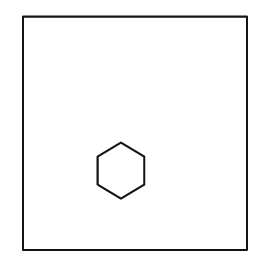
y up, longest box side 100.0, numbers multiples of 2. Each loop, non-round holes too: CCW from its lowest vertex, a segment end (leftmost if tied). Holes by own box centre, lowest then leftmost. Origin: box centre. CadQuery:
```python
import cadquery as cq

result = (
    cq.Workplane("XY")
    .moveTo(-48.0, -50.0)
    .lineTo(48.0, -50.0)
    .lineTo(48.0, 50.0)
    .lineTo(-48.0, 50.0)
    .close()
    .moveTo(-6.0, -28.0)
    .lineTo(4.0, -22.0)
    .lineTo(4.0, -10.0)
    .lineTo(-6.0, -4.0)
    .lineTo(-16.0, -10.0)
    .lineTo(-16.0, -22.0)
    .close()
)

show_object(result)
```